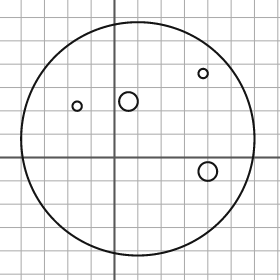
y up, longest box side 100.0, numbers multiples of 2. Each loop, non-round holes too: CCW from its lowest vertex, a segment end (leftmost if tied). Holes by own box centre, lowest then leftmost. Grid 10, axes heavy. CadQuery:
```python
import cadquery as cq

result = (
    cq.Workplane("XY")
    .moveTo(10.0, 8.0)
    .circle(50.0)
    .moveTo(40.0, -6.0)
    .circle(4.0)
    .moveTo(-16.0, 22.0)
    .circle(2.0)
    .moveTo(6.0, 24.0)
    .circle(4.0)
    .moveTo(38.0, 36.0)
    .circle(2.0)
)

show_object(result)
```